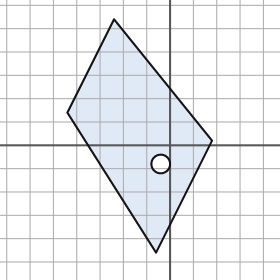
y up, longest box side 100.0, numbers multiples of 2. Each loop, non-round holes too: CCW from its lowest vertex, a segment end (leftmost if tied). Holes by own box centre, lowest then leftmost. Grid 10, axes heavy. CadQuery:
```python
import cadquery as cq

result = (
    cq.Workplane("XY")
    .moveTo(-6.0, -46.0)
    .lineTo(18.0, 2.0)
    .lineTo(-24.0, 54.0)
    .lineTo(-44.0, 14.0)
    .close()
    .moveTo(-4.0, -8.0)
    .circle(4.0)
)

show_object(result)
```